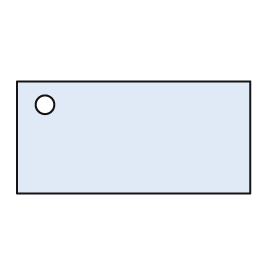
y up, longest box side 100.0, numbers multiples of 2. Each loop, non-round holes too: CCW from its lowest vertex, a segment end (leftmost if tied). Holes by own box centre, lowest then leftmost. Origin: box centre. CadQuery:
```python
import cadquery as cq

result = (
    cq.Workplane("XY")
    .moveTo(-50.0, -24.0)
    .lineTo(50.0, -24.0)
    .lineTo(50.0, 24.0)
    .lineTo(-50.0, 24.0)
    .close()
    .moveTo(-38.0, 14.0)
    .circle(4.0)
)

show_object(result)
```